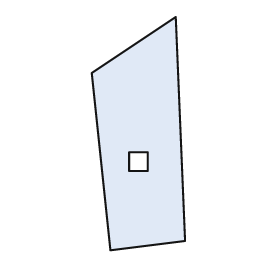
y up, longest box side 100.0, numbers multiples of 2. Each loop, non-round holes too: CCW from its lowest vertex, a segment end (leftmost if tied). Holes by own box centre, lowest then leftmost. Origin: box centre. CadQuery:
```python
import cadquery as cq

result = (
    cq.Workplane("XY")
    .moveTo(-12.0, -50.0)
    .lineTo(20.0, -46.0)
    .lineTo(16.0, 50.0)
    .lineTo(-20.0, 26.0)
    .close()
    .moveTo(-4.0, -16.0)
    .lineTo(4.0, -16.0)
    .lineTo(4.0, -8.0)
    .lineTo(-4.0, -8.0)
    .close()
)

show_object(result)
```